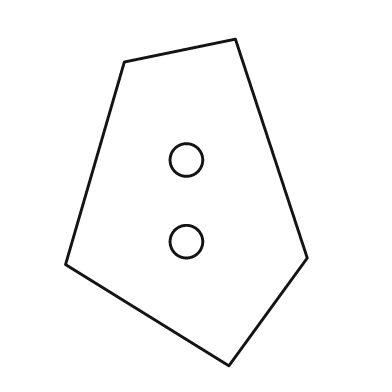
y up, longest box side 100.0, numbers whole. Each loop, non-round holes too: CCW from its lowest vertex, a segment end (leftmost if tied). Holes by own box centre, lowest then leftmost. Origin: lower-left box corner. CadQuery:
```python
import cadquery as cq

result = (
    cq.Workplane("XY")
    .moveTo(50.0, 0.0)
    .lineTo(74.0, 33.0)
    .lineTo(52.0, 100.0)
    .lineTo(18.0, 93.0)
    .lineTo(0.0, 31.0)
    .close()
    .moveTo(37.0, 38.0)
    .circle(5.0)
    .moveTo(37.0, 63.0)
    .circle(5.0)
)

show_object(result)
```